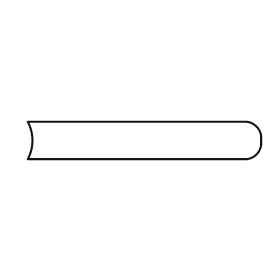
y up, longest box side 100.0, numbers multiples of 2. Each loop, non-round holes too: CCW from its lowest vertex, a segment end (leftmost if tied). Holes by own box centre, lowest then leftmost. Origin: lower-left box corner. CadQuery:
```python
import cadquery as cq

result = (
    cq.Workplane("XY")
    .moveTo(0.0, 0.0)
    .lineTo(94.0, 0.0)
    .threePointArc((98.0, 2.0), (100.0, 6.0))
    .lineTo(100.0, 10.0)
    .threePointArc((98.0, 14.0), (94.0, 16.0))
    .lineTo(0.0, 16.0)
    .threePointArc((2.0, 8.0), (0.0, 0.0))
    .close()
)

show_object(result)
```